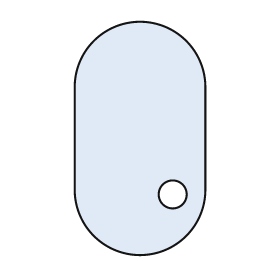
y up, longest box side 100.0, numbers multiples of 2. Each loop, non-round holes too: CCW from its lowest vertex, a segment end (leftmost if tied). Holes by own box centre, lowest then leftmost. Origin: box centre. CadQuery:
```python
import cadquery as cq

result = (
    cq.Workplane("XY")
    .moveTo(-28.0, -22.0)
    .threePointArc((0.0, -50.0), (28.0, -22.0))
    .lineTo(28.0, 22.0)
    .threePointArc((0.0, 50.0), (-28.0, 22.0))
    .close()
    .moveTo(14.0, -24.0)
    .circle(6.0)
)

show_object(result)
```